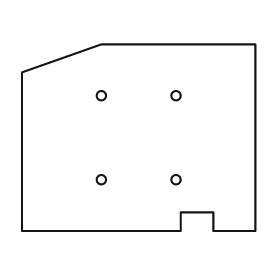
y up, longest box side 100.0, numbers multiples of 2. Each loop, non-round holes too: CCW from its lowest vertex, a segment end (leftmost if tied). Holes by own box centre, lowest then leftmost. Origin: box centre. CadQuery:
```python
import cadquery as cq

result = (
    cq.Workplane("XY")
    .moveTo(-50.0, -40.0)
    .lineTo(18.0, -40.0)
    .lineTo(18.0, -32.0)
    .lineTo(32.0, -32.0)
    .lineTo(32.0, -40.0)
    .lineTo(50.0, -40.0)
    .lineTo(50.0, 40.0)
    .lineTo(-16.0, 40.0)
    .lineTo(-50.0, 28.0)
    .close()
    .moveTo(-16.0, -18.0)
    .circle(2.0)
    .moveTo(16.0, -18.0)
    .circle(2.0)
    .moveTo(-16.0, 18.0)
    .circle(2.0)
    .moveTo(16.0, 18.0)
    .circle(2.0)
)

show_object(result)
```